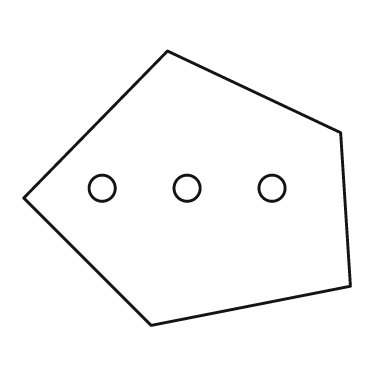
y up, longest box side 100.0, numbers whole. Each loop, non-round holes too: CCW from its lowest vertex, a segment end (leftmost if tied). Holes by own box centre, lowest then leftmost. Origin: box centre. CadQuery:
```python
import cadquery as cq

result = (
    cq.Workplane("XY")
    .moveTo(-11.0, -42.0)
    .lineTo(50.0, -30.0)
    .lineTo(47.0, 17.0)
    .lineTo(-6.0, 42.0)
    .lineTo(-50.0, -3.0)
    .close()
    .moveTo(-26.0, 0.0)
    .circle(4.0)
    .moveTo(0.0, 0.0)
    .circle(4.0)
    .moveTo(26.0, 0.0)
    .circle(4.0)
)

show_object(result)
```